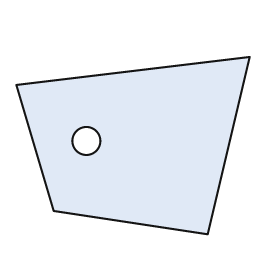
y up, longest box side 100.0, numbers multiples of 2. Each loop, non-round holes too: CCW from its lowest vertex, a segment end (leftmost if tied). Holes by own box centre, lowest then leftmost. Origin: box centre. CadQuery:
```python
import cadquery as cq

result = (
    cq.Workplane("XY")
    .moveTo(32.0, -38.0)
    .lineTo(50.0, 38.0)
    .lineTo(-50.0, 26.0)
    .lineTo(-34.0, -28.0)
    .close()
    .moveTo(-20.0, 2.0)
    .circle(6.0)
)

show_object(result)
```